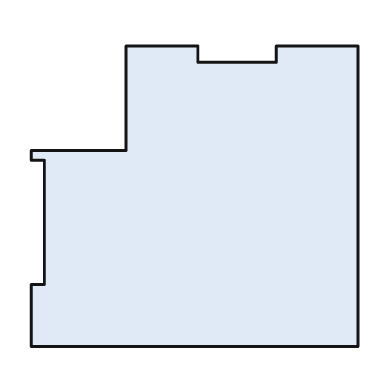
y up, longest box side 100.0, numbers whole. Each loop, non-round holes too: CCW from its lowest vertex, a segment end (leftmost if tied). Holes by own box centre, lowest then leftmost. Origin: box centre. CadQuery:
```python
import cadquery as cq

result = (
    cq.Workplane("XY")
    .moveTo(-50.0, -46.0)
    .lineTo(50.0, -46.0)
    .lineTo(50.0, 46.0)
    .lineTo(25.0, 46.0)
    .lineTo(25.0, 41.0)
    .lineTo(1.0, 41.0)
    .lineTo(1.0, 46.0)
    .lineTo(-21.0, 46.0)
    .lineTo(-21.0, 14.0)
    .lineTo(-50.0, 14.0)
    .lineTo(-50.0, 11.0)
    .lineTo(-46.0, 11.0)
    .lineTo(-46.0, -27.0)
    .lineTo(-50.0, -27.0)
    .close()
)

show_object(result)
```